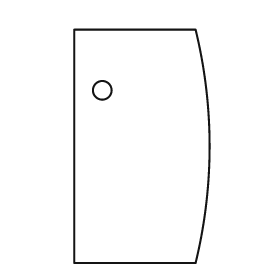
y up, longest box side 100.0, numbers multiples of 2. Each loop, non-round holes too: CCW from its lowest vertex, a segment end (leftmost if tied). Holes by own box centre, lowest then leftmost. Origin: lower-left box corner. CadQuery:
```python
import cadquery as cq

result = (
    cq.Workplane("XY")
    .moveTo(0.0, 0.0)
    .lineTo(52.0, 0.0)
    .threePointArc((58.0, 50.0), (52.0, 100.0))
    .lineTo(0.0, 100.0)
    .close()
    .moveTo(12.0, 74.0)
    .circle(4.0)
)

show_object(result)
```